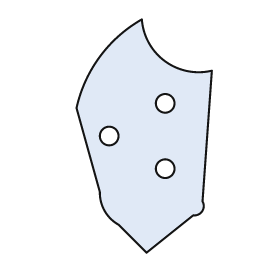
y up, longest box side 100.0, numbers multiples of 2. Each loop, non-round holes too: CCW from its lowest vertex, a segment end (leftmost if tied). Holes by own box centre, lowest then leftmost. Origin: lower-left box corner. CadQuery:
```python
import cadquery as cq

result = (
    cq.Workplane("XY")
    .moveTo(30.0, 0.0)
    .lineTo(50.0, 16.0)
    .threePointArc((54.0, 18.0), (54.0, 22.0))
    .lineTo(58.0, 78.0)
    .threePointArc((38.0, 82.0), (28.0, 100.0))
    .threePointArc((10.0, 84.0), (0.0, 62.0))
    .lineTo(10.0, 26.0)
    .threePointArc((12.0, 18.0), (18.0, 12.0))
    .close()
    .moveTo(38.0, 36.0)
    .circle(4.0)
    .moveTo(14.0, 50.0)
    .circle(4.0)
    .moveTo(38.0, 64.0)
    .circle(4.0)
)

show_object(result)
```